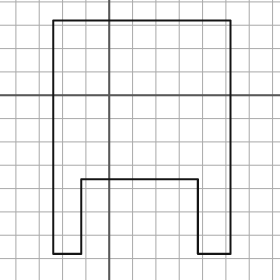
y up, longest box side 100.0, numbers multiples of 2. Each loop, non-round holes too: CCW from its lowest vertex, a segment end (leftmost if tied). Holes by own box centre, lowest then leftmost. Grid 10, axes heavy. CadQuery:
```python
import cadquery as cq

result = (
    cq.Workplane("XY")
    .moveTo(-24.0, -68.0)
    .lineTo(-12.0, -68.0)
    .lineTo(-12.0, -36.0)
    .lineTo(38.0, -36.0)
    .lineTo(38.0, -68.0)
    .lineTo(52.0, -68.0)
    .lineTo(52.0, 32.0)
    .lineTo(-24.0, 32.0)
    .close()
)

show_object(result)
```